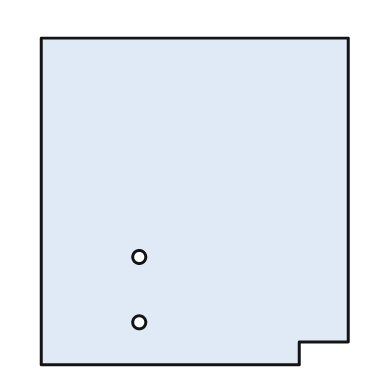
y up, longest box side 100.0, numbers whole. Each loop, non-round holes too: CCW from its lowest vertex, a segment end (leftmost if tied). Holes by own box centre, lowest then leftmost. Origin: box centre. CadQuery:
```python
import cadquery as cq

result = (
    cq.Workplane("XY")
    .moveTo(-47.0, -50.0)
    .lineTo(32.0, -50.0)
    .lineTo(32.0, -43.0)
    .lineTo(47.0, -43.0)
    .lineTo(47.0, 50.0)
    .lineTo(-47.0, 50.0)
    .close()
    .moveTo(-17.0, -37.0)
    .circle(2.0)
    .moveTo(-17.0, -17.0)
    .circle(2.0)
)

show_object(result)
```